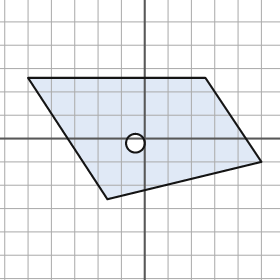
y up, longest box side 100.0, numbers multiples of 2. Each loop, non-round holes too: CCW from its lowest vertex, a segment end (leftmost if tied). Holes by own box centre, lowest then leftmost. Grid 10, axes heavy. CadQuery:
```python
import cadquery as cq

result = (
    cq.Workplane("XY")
    .moveTo(-16.0, -26.0)
    .lineTo(50.0, -10.0)
    .lineTo(26.0, 26.0)
    .lineTo(-50.0, 26.0)
    .close()
    .moveTo(-4.0, -2.0)
    .circle(4.0)
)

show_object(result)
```